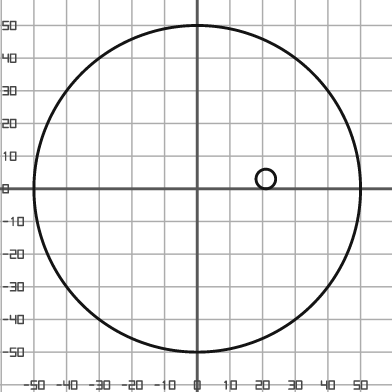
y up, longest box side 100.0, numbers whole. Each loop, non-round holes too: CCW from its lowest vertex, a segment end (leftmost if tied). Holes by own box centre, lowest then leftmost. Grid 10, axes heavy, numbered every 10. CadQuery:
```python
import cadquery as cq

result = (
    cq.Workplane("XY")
    .moveTo(0.0, 0.0)
    .circle(50.0)
    .moveTo(21.0, 3.0)
    .circle(3.0)
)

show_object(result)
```